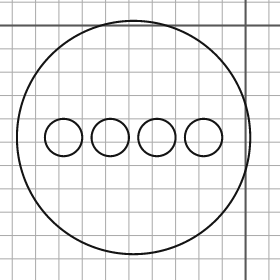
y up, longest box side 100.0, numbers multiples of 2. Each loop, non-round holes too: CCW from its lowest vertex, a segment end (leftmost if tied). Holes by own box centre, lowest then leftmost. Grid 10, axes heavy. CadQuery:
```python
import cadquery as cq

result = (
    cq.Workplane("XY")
    .moveTo(-48.0, -48.0)
    .circle(50.0)
    .moveTo(-78.0, -48.0)
    .circle(8.0)
    .moveTo(-58.0, -48.0)
    .circle(8.0)
    .moveTo(-38.0, -48.0)
    .circle(8.0)
    .moveTo(-18.0, -48.0)
    .circle(8.0)
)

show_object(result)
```